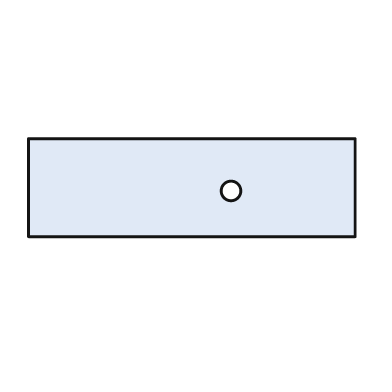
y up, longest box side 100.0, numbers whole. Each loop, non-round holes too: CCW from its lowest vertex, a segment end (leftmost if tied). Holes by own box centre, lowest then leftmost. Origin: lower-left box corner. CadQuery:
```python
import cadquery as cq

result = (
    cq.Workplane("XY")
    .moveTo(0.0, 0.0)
    .lineTo(100.0, 0.0)
    .lineTo(100.0, 30.0)
    .lineTo(0.0, 30.0)
    .close()
    .moveTo(62.0, 14.0)
    .circle(3.0)
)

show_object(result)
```